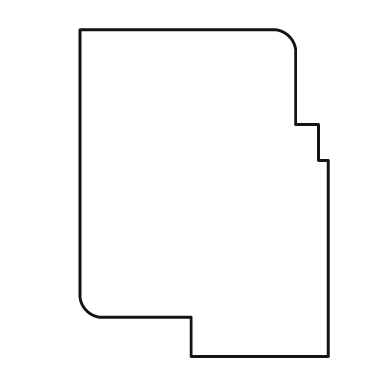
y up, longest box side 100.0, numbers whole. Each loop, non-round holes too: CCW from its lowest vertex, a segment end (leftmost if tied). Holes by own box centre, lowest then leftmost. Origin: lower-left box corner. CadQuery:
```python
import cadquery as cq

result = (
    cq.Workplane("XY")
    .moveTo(34.0, 0.0)
    .lineTo(76.0, 0.0)
    .lineTo(76.0, 60.0)
    .lineTo(73.0, 60.0)
    .lineTo(73.0, 71.0)
    .lineTo(66.0, 71.0)
    .lineTo(66.0, 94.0)
    .threePointArc((64.0, 98.0), (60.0, 100.0))
    .lineTo(0.0, 100.0)
    .lineTo(0.0, 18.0)
    .threePointArc((2.0, 14.0), (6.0, 12.0))
    .lineTo(34.0, 12.0)
    .close()
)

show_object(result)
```